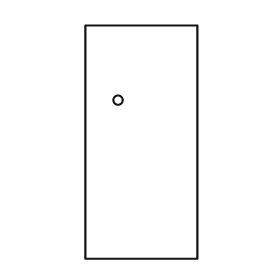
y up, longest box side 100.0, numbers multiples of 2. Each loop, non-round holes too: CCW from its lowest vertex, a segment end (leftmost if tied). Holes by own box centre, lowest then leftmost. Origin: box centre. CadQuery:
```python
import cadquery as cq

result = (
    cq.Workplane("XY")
    .moveTo(-24.0, -50.0)
    .lineTo(24.0, -50.0)
    .lineTo(24.0, 50.0)
    .lineTo(-24.0, 50.0)
    .close()
    .moveTo(-10.0, 18.0)
    .circle(2.0)
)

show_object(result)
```